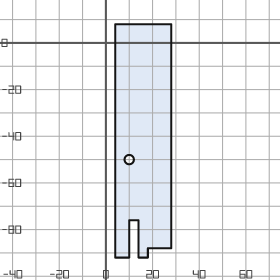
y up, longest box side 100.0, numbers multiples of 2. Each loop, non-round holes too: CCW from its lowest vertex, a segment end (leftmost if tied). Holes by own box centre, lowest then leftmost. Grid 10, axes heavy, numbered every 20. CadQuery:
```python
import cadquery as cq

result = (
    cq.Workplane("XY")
    .moveTo(4.0, -92.0)
    .lineTo(10.0, -92.0)
    .lineTo(10.0, -76.0)
    .lineTo(14.0, -76.0)
    .lineTo(14.0, -92.0)
    .lineTo(18.0, -92.0)
    .lineTo(18.0, -88.0)
    .lineTo(28.0, -88.0)
    .lineTo(28.0, 8.0)
    .lineTo(4.0, 8.0)
    .close()
    .moveTo(10.0, -50.0)
    .circle(2.0)
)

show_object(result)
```